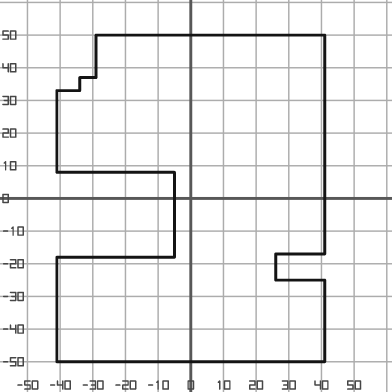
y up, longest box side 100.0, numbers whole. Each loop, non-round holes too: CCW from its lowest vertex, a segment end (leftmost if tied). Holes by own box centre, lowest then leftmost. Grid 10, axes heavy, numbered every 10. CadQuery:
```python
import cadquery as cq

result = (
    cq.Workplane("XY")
    .moveTo(-41.0, -50.0)
    .lineTo(41.0, -50.0)
    .lineTo(41.0, -25.0)
    .lineTo(26.0, -25.0)
    .lineTo(26.0, -17.0)
    .lineTo(41.0, -17.0)
    .lineTo(41.0, 50.0)
    .lineTo(-29.0, 50.0)
    .lineTo(-29.0, 37.0)
    .lineTo(-34.0, 37.0)
    .lineTo(-34.0, 33.0)
    .lineTo(-41.0, 33.0)
    .lineTo(-41.0, 8.0)
    .lineTo(-5.0, 8.0)
    .lineTo(-5.0, -18.0)
    .lineTo(-41.0, -18.0)
    .close()
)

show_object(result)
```